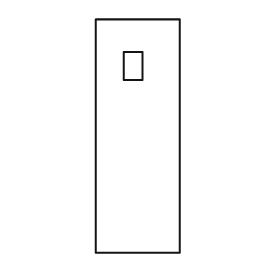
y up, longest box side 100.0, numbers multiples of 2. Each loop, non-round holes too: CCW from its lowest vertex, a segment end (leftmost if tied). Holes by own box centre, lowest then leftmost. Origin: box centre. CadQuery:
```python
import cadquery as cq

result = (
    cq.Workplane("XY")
    .moveTo(-18.0, -50.0)
    .lineTo(18.0, -50.0)
    .lineTo(18.0, 50.0)
    .lineTo(-18.0, 50.0)
    .close()
    .moveTo(-6.0, 24.0)
    .lineTo(2.0, 24.0)
    .lineTo(2.0, 36.0)
    .lineTo(-6.0, 36.0)
    .close()
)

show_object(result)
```